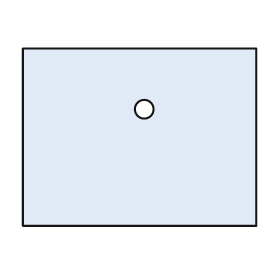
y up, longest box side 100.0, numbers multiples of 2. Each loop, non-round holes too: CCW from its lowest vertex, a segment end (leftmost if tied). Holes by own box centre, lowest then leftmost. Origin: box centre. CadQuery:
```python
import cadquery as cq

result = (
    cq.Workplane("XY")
    .moveTo(-50.0, -38.0)
    .lineTo(50.0, -38.0)
    .lineTo(50.0, 38.0)
    .lineTo(-50.0, 38.0)
    .close()
    .moveTo(2.0, 12.0)
    .circle(4.0)
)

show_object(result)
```